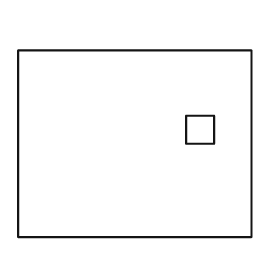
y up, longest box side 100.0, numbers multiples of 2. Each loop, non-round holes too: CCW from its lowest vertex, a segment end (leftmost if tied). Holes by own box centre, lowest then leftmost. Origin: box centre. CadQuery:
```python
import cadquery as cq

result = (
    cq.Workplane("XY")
    .moveTo(-50.0, -40.0)
    .lineTo(50.0, -40.0)
    .lineTo(50.0, 40.0)
    .lineTo(-50.0, 40.0)
    .close()
    .moveTo(22.0, 0.0)
    .lineTo(34.0, 0.0)
    .lineTo(34.0, 12.0)
    .lineTo(22.0, 12.0)
    .close()
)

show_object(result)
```